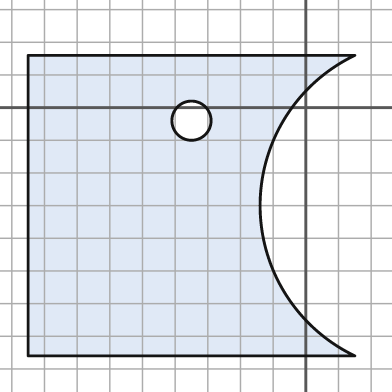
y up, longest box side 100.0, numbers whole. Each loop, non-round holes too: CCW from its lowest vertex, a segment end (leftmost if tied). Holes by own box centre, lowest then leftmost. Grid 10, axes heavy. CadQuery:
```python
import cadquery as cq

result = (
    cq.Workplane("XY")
    .moveTo(-85.0, -76.0)
    .lineTo(15.0, -76.0)
    .threePointArc((-14.0, -30.0), (15.0, 16.0))
    .lineTo(-85.0, 16.0)
    .close()
    .moveTo(-35.0, -4.0)
    .circle(6.0)
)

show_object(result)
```